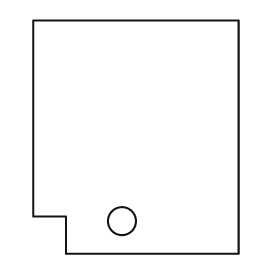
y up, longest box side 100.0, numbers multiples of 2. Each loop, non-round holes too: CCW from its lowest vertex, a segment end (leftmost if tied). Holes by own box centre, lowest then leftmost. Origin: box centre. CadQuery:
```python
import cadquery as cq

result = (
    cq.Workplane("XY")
    .moveTo(-30.0, -50.0)
    .lineTo(44.0, -50.0)
    .lineTo(44.0, 50.0)
    .lineTo(-44.0, 50.0)
    .lineTo(-44.0, -34.0)
    .lineTo(-30.0, -34.0)
    .close()
    .moveTo(-6.0, -36.0)
    .circle(6.0)
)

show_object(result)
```